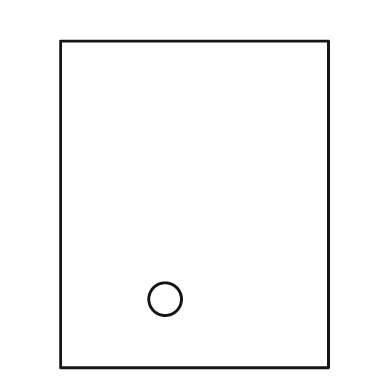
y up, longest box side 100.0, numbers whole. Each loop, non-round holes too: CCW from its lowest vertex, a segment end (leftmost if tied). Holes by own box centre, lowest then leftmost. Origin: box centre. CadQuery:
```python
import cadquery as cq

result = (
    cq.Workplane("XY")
    .moveTo(-41.0, -50.0)
    .lineTo(41.0, -50.0)
    .lineTo(41.0, 50.0)
    .lineTo(-41.0, 50.0)
    .close()
    .moveTo(-9.0, -29.0)
    .circle(5.0)
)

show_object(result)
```